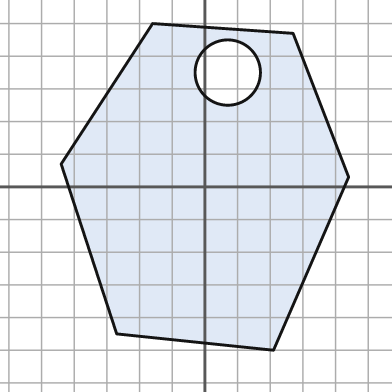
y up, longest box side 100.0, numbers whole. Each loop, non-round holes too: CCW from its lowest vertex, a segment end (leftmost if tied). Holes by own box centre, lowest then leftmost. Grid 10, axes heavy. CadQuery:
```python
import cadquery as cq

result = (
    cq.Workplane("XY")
    .moveTo(21.0, -50.0)
    .lineTo(44.0, 3.0)
    .lineTo(27.0, 47.0)
    .lineTo(-16.0, 50.0)
    .lineTo(-44.0, 7.0)
    .lineTo(-27.0, -45.0)
    .close()
    .moveTo(7.0, 35.0)
    .circle(10.0)
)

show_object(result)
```